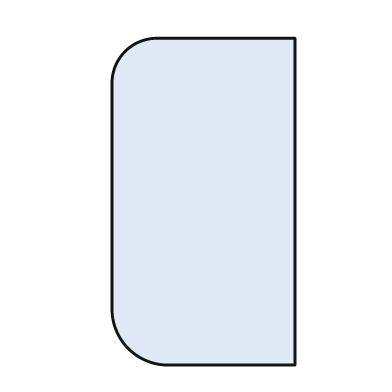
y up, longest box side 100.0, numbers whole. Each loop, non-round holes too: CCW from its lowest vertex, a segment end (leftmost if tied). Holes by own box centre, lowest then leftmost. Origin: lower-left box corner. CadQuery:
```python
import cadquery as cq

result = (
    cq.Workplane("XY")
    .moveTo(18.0, 0.0)
    .lineTo(56.0, 0.0)
    .lineTo(56.0, 100.0)
    .lineTo(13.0, 100.0)
    .threePointArc((4.0, 96.0), (0.0, 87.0))
    .lineTo(0.0, 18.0)
    .threePointArc((5.0, 5.0), (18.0, 0.0))
    .close()
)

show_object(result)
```